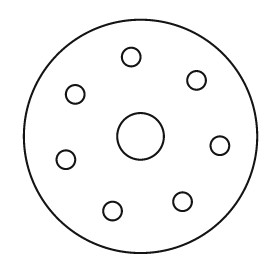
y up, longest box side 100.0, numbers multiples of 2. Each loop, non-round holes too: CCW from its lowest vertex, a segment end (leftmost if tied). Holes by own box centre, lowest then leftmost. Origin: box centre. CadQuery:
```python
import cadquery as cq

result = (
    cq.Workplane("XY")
    .moveTo(0.0, 0.0)
    .circle(50.0)
    .moveTo(-12.0, -32.0)
    .circle(4.0)
    .moveTo(18.0, -28.0)
    .circle(4.0)
    .moveTo(-32.0, -10.0)
    .circle(4.0)
    .moveTo(34.0, -4.0)
    .circle(4.0)
    .moveTo(0.0, 0.0)
    .circle(10.0)
    .moveTo(-28.0, 18.0)
    .circle(4.0)
    .moveTo(24.0, 24.0)
    .circle(4.0)
    .moveTo(-4.0, 34.0)
    .circle(4.0)
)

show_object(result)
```